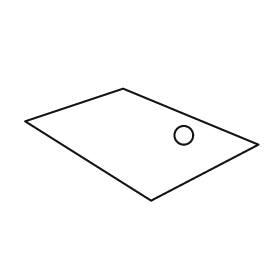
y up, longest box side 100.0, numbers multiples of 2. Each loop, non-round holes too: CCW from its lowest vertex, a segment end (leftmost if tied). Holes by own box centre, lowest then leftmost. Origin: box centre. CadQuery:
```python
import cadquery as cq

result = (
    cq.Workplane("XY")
    .moveTo(4.0, -24.0)
    .lineTo(50.0, 0.0)
    .lineTo(-8.0, 24.0)
    .lineTo(-50.0, 10.0)
    .close()
    .moveTo(18.0, 4.0)
    .circle(4.0)
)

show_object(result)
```